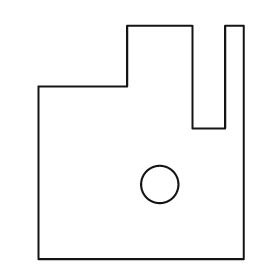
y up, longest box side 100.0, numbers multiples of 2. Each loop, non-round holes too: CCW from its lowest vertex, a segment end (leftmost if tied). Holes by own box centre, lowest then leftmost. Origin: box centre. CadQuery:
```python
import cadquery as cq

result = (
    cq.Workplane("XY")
    .moveTo(-44.0, -50.0)
    .lineTo(44.0, -50.0)
    .lineTo(44.0, 50.0)
    .lineTo(36.0, 50.0)
    .lineTo(36.0, 6.0)
    .lineTo(22.0, 6.0)
    .lineTo(22.0, 50.0)
    .lineTo(-6.0, 50.0)
    .lineTo(-6.0, 24.0)
    .lineTo(-44.0, 24.0)
    .close()
    .moveTo(8.0, -18.0)
    .circle(8.0)
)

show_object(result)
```